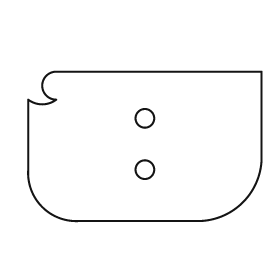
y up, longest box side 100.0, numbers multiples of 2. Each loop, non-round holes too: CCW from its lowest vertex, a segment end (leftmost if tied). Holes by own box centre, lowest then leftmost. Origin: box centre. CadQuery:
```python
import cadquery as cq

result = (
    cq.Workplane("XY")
    .moveTo(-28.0, -32.0)
    .lineTo(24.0, -32.0)
    .threePointArc((42.0, -24.0), (50.0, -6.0))
    .lineTo(50.0, 32.0)
    .lineTo(-38.0, 32.0)
    .threePointArc((-44.0, 26.0), (-38.0, 20.0))
    .threePointArc((-44.0, 18.0), (-50.0, 20.0))
    .lineTo(-50.0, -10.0)
    .threePointArc((-44.0, -26.0), (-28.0, -32.0))
    .close()
    .moveTo(0.0, -10.0)
    .circle(4.0)
    .moveTo(0.0, 12.0)
    .circle(4.0)
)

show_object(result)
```